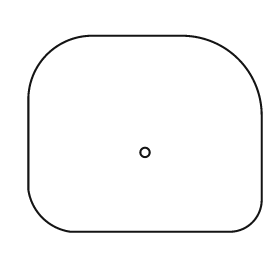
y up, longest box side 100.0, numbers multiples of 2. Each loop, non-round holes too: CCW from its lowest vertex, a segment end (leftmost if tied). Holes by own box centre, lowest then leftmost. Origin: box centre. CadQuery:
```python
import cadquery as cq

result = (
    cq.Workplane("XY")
    .moveTo(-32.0, -42.0)
    .lineTo(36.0, -42.0)
    .threePointArc((46.0, -38.0), (50.0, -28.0))
    .lineTo(50.0, 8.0)
    .threePointArc((40.0, 32.0), (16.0, 42.0))
    .lineTo(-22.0, 42.0)
    .threePointArc((-42.0, 34.0), (-50.0, 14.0))
    .lineTo(-50.0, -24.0)
    .threePointArc((-44.0, -36.0), (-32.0, -42.0))
    .close()
    .moveTo(0.0, -8.0)
    .circle(2.0)
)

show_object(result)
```